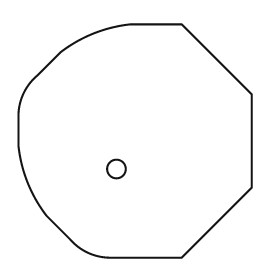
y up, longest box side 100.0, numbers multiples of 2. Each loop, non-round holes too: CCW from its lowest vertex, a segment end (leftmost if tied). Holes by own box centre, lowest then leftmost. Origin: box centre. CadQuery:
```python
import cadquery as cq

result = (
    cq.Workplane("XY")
    .moveTo(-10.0, -50.0)
    .lineTo(20.0, -50.0)
    .lineTo(50.0, -20.0)
    .lineTo(50.0, 20.0)
    .lineTo(20.0, 50.0)
    .lineTo(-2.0, 50.0)
    .threePointArc((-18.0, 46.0), (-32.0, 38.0))
    .lineTo(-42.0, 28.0)
    .threePointArc((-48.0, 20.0), (-50.0, 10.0))
    .lineTo(-50.0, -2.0)
    .threePointArc((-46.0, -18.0), (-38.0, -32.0))
    .lineTo(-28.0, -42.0)
    .threePointArc((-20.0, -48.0), (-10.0, -50.0))
    .close()
    .moveTo(-8.0, -12.0)
    .circle(4.0)
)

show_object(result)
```